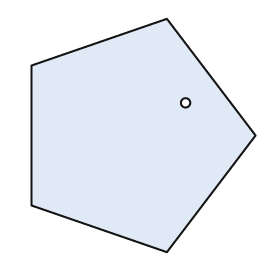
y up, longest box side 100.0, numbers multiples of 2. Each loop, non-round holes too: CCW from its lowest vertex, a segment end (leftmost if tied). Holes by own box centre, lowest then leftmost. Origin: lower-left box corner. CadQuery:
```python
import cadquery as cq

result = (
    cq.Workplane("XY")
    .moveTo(58.0, 0.0)
    .lineTo(96.0, 50.0)
    .lineTo(58.0, 100.0)
    .lineTo(0.0, 80.0)
    .lineTo(0.0, 20.0)
    .close()
    .moveTo(66.0, 64.0)
    .circle(2.0)
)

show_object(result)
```